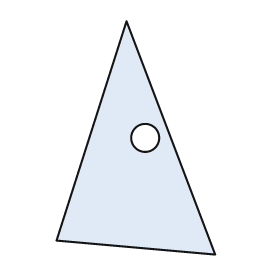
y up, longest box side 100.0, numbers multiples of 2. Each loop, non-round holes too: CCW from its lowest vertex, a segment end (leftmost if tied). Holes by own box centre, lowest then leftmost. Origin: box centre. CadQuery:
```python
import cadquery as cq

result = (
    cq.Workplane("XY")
    .moveTo(34.0, -50.0)
    .lineTo(-4.0, 50.0)
    .lineTo(-34.0, -44.0)
    .close()
    .moveTo(4.0, 0.0)
    .circle(6.0)
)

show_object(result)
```